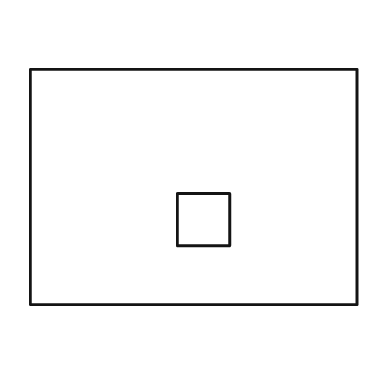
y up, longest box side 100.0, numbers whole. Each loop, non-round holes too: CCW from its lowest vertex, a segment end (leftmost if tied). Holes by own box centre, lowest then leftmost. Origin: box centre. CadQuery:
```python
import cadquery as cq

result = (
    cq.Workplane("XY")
    .moveTo(-50.0, -36.0)
    .lineTo(50.0, -36.0)
    .lineTo(50.0, 36.0)
    .lineTo(-50.0, 36.0)
    .close()
    .moveTo(-5.0, -18.0)
    .lineTo(11.0, -18.0)
    .lineTo(11.0, -2.0)
    .lineTo(-5.0, -2.0)
    .close()
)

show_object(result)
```